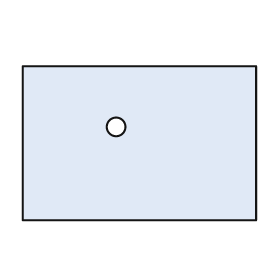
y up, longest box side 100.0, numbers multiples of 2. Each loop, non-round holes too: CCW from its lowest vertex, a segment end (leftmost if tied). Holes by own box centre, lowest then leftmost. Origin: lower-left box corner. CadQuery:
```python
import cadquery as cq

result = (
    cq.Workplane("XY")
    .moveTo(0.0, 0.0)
    .lineTo(100.0, 0.0)
    .lineTo(100.0, 66.0)
    .lineTo(0.0, 66.0)
    .close()
    .moveTo(40.0, 40.0)
    .circle(4.0)
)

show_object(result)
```